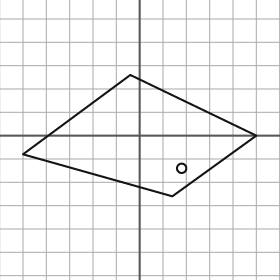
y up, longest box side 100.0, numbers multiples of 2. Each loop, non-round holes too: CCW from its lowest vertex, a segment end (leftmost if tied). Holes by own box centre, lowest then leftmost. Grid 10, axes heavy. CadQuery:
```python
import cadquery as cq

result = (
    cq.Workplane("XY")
    .moveTo(14.0, -26.0)
    .lineTo(50.0, 0.0)
    .lineTo(-4.0, 26.0)
    .lineTo(-50.0, -8.0)
    .close()
    .moveTo(18.0, -14.0)
    .circle(2.0)
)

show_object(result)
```